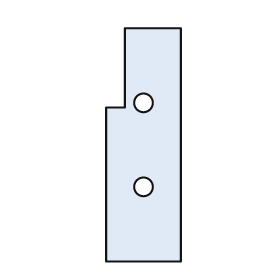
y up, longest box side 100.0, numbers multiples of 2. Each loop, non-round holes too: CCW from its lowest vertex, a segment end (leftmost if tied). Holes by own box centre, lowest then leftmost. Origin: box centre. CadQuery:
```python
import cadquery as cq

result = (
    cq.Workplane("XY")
    .moveTo(-16.0, -50.0)
    .lineTo(16.0, -50.0)
    .lineTo(16.0, 50.0)
    .lineTo(-8.0, 50.0)
    .lineTo(-8.0, 16.0)
    .lineTo(-16.0, 16.0)
    .close()
    .moveTo(0.0, -18.0)
    .circle(4.0)
    .moveTo(0.0, 18.0)
    .circle(4.0)
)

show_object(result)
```